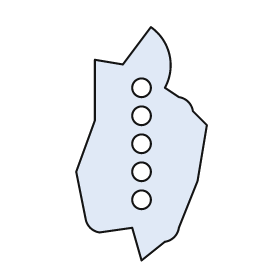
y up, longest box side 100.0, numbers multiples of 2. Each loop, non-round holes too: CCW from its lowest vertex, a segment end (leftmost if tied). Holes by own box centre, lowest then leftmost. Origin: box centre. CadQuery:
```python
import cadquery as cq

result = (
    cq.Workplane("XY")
    .moveTo(0.0, -50.0)
    .lineTo(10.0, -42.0)
    .threePointArc((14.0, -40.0), (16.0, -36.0))
    .lineTo(24.0, -16.0)
    .lineTo(28.0, 8.0)
    .lineTo(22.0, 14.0)
    .threePointArc((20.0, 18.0), (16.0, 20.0))
    .lineTo(10.0, 24.0)
    .threePointArc((12.0, 38.0), (4.0, 50.0))
    .lineTo(-8.0, 34.0)
    .lineTo(-20.0, 36.0)
    .lineTo(-20.0, 10.0)
    .lineTo(-28.0, -12.0)
    .lineTo(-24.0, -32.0)
    .threePointArc((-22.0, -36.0), (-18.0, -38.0))
    .lineTo(-4.0, -36.0)
    .close()
    .moveTo(0.0, -24.0)
    .circle(4.0)
    .moveTo(0.0, -12.0)
    .circle(4.0)
    .moveTo(0.0, 0.0)
    .circle(4.0)
    .moveTo(0.0, 12.0)
    .circle(4.0)
    .moveTo(0.0, 24.0)
    .circle(4.0)
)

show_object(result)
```